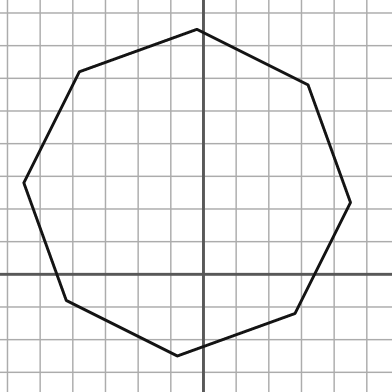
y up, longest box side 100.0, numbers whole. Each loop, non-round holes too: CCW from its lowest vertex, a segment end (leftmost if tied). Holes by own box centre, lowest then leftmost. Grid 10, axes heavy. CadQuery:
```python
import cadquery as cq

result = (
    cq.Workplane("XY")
    .moveTo(-8.0, -25.0)
    .lineTo(28.0, -12.0)
    .lineTo(45.0, 22.0)
    .lineTo(32.0, 58.0)
    .lineTo(-2.0, 75.0)
    .lineTo(-38.0, 62.0)
    .lineTo(-55.0, 28.0)
    .lineTo(-42.0, -8.0)
    .close()
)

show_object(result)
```